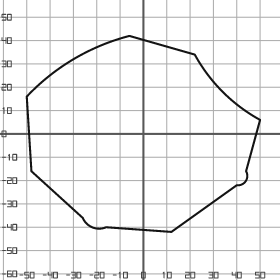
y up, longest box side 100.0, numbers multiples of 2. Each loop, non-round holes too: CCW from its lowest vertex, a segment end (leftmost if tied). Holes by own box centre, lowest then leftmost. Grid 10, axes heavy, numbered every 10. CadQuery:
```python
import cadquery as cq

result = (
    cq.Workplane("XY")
    .moveTo(12.0, -42.0)
    .lineTo(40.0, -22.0)
    .threePointArc((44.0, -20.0), (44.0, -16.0))
    .lineTo(50.0, 6.0)
    .threePointArc((34.0, 18.0), (22.0, 34.0))
    .lineTo(-6.0, 42.0)
    .threePointArc((-30.0, 32.0), (-50.0, 16.0))
    .lineTo(-48.0, -16.0)
    .lineTo(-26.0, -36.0)
    .threePointArc((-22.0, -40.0), (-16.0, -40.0))
    .close()
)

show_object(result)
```